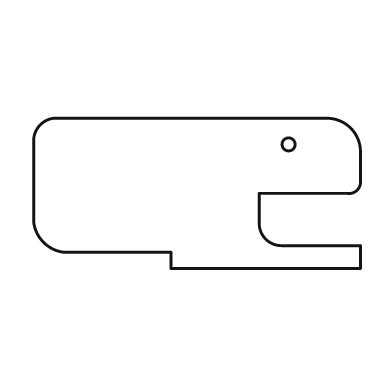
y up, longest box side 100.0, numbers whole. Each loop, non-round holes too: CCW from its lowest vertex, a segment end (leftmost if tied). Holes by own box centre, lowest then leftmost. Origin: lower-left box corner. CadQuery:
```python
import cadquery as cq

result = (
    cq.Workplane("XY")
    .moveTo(42.0, 0.0)
    .lineTo(100.0, 0.0)
    .lineTo(100.0, 7.0)
    .lineTo(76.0, 7.0)
    .threePointArc((71.0, 9.0), (69.0, 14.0))
    .lineTo(69.0, 23.0)
    .lineTo(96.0, 23.0)
    .threePointArc((99.0, 24.0), (100.0, 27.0))
    .lineTo(100.0, 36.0)
    .threePointArc((97.0, 43.0), (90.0, 46.0))
    .lineTo(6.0, 46.0)
    .threePointArc((2.0, 44.0), (0.0, 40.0))
    .lineTo(0.0, 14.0)
    .threePointArc((3.0, 8.0), (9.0, 5.0))
    .lineTo(42.0, 5.0)
    .close()
    .moveTo(78.0, 38.0)
    .circle(2.0)
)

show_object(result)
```